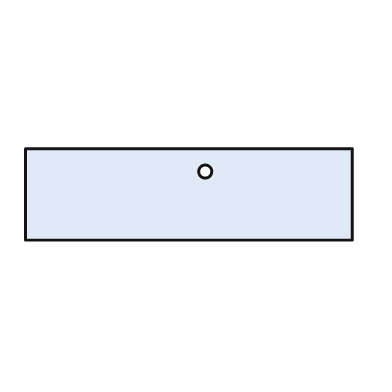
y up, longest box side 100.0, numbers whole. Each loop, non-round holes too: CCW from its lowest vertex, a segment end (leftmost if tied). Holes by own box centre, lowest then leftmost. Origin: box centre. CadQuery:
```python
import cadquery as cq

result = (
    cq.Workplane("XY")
    .moveTo(-50.0, -14.0)
    .lineTo(50.0, -14.0)
    .lineTo(50.0, 14.0)
    .lineTo(-50.0, 14.0)
    .close()
    .moveTo(5.0, 7.0)
    .circle(2.0)
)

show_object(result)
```